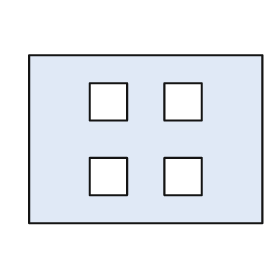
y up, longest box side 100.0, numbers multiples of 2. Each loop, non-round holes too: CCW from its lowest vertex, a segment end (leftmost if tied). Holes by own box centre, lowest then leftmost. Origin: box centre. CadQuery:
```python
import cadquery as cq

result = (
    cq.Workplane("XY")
    .moveTo(-50.0, -36.0)
    .lineTo(50.0, -36.0)
    .lineTo(50.0, 36.0)
    .lineTo(-50.0, 36.0)
    .close()
    .moveTo(-24.0, -24.0)
    .lineTo(-8.0, -24.0)
    .lineTo(-8.0, -8.0)
    .lineTo(-24.0, -8.0)
    .close()
    .moveTo(8.0, -24.0)
    .lineTo(24.0, -24.0)
    .lineTo(24.0, -8.0)
    .lineTo(8.0, -8.0)
    .close()
    .moveTo(-24.0, 8.0)
    .lineTo(-8.0, 8.0)
    .lineTo(-8.0, 24.0)
    .lineTo(-24.0, 24.0)
    .close()
    .moveTo(8.0, 8.0)
    .lineTo(24.0, 8.0)
    .lineTo(24.0, 24.0)
    .lineTo(8.0, 24.0)
    .close()
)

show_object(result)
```